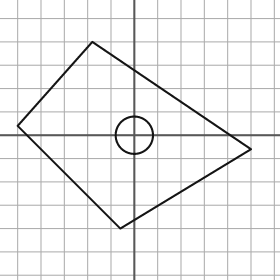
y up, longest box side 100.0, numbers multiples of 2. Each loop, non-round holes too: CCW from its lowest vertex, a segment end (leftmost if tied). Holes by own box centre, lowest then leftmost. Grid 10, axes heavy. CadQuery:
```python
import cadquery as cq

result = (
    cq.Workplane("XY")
    .moveTo(-6.0, -40.0)
    .lineTo(50.0, -6.0)
    .lineTo(-18.0, 40.0)
    .lineTo(-50.0, 4.0)
    .close()
    .moveTo(0.0, 0.0)
    .circle(8.0)
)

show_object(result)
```